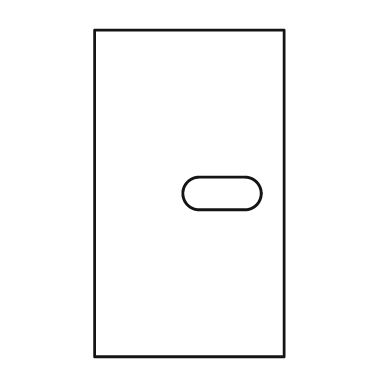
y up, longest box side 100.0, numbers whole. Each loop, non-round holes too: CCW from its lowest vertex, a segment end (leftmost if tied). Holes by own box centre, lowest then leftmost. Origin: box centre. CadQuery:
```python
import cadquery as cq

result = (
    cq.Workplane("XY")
    .moveTo(-29.0, -50.0)
    .lineTo(29.0, -50.0)
    .lineTo(29.0, 50.0)
    .lineTo(-29.0, 50.0)
    .close()
    .moveTo(3.0, -5.0)
    .lineTo(17.0, -5.0)
    .threePointArc((22.0, 0.0), (17.0, 5.0))
    .lineTo(3.0, 5.0)
    .threePointArc((-2.0, 0.0), (3.0, -5.0))
    .close()
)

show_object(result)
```